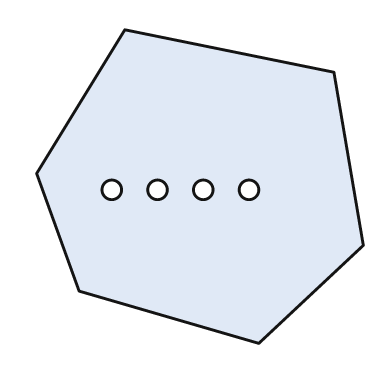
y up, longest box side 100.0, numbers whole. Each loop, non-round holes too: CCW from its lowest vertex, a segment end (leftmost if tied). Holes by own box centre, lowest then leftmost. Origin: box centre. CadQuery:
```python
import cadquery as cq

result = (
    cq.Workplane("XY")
    .moveTo(18.0, -48.0)
    .lineTo(50.0, -18.0)
    .lineTo(41.0, 35.0)
    .lineTo(-23.0, 48.0)
    .lineTo(-50.0, 4.0)
    .lineTo(-37.0, -32.0)
    .close()
    .moveTo(-27.0, -1.0)
    .circle(3.0)
    .moveTo(-13.0, -1.0)
    .circle(3.0)
    .moveTo(1.0, -1.0)
    .circle(3.0)
    .moveTo(15.0, -1.0)
    .circle(3.0)
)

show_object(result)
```